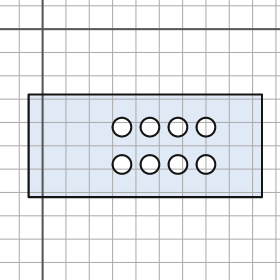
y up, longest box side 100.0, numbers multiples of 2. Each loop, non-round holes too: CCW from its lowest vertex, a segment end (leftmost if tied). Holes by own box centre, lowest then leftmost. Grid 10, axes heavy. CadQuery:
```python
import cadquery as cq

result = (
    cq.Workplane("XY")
    .moveTo(-6.0, -72.0)
    .lineTo(94.0, -72.0)
    .lineTo(94.0, -28.0)
    .lineTo(-6.0, -28.0)
    .close()
    .moveTo(34.0, -58.0)
    .circle(4.0)
    .moveTo(46.0, -58.0)
    .circle(4.0)
    .moveTo(58.0, -58.0)
    .circle(4.0)
    .moveTo(70.0, -58.0)
    .circle(4.0)
    .moveTo(34.0, -42.0)
    .circle(4.0)
    .moveTo(46.0, -42.0)
    .circle(4.0)
    .moveTo(58.0, -42.0)
    .circle(4.0)
    .moveTo(70.0, -42.0)
    .circle(4.0)
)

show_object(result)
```